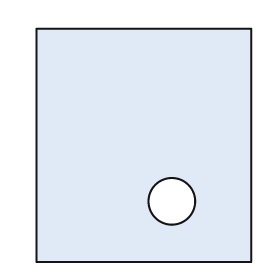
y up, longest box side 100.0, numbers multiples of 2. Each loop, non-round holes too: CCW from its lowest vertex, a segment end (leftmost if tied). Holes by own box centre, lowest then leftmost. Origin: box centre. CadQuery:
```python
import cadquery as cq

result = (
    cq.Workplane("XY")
    .moveTo(-46.0, -50.0)
    .lineTo(46.0, -50.0)
    .lineTo(46.0, 50.0)
    .lineTo(-46.0, 50.0)
    .close()
    .moveTo(12.0, -24.0)
    .circle(10.0)
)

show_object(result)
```